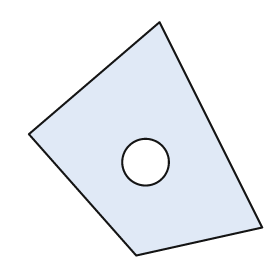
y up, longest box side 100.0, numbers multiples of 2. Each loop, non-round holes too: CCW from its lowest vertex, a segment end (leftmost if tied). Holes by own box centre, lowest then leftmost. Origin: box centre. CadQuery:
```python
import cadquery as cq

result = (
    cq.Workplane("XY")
    .moveTo(-4.0, -50.0)
    .lineTo(50.0, -38.0)
    .lineTo(6.0, 50.0)
    .lineTo(-50.0, 2.0)
    .close()
    .moveTo(0.0, -10.0)
    .circle(10.0)
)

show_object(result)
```